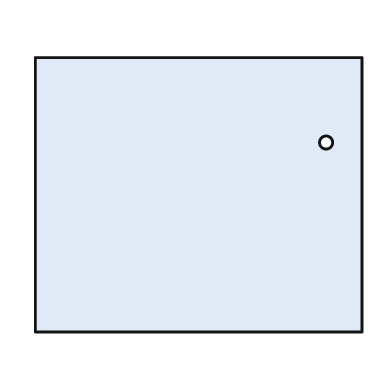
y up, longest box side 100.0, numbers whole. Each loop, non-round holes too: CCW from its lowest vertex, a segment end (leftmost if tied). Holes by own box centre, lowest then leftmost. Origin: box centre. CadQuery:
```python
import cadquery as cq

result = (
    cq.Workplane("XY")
    .moveTo(-50.0, -42.0)
    .lineTo(50.0, -42.0)
    .lineTo(50.0, 42.0)
    .lineTo(-50.0, 42.0)
    .close()
    .moveTo(39.0, 16.0)
    .circle(2.0)
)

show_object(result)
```